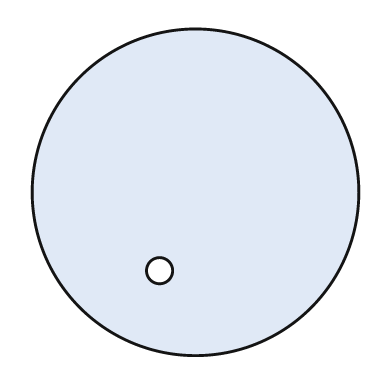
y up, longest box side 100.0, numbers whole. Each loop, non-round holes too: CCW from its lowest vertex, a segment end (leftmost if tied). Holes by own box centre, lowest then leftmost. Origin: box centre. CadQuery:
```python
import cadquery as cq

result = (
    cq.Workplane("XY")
    .moveTo(0.0, 0.0)
    .circle(50.0)
    .moveTo(-11.0, -24.0)
    .circle(4.0)
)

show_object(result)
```